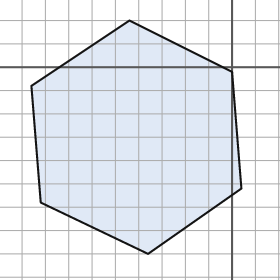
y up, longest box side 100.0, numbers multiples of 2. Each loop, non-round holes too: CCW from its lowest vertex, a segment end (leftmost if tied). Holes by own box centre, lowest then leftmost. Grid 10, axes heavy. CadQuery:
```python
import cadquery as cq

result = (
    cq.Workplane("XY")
    .moveTo(-36.0, -80.0)
    .lineTo(4.0, -52.0)
    .lineTo(0.0, -2.0)
    .lineTo(-44.0, 20.0)
    .lineTo(-86.0, -8.0)
    .lineTo(-82.0, -58.0)
    .close()
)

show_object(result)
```